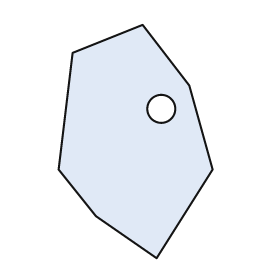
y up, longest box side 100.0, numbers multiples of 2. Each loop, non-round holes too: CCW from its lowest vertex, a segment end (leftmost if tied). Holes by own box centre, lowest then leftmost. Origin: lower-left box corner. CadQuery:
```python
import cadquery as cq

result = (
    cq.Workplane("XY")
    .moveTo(42.0, 0.0)
    .lineTo(66.0, 38.0)
    .lineTo(56.0, 74.0)
    .lineTo(36.0, 100.0)
    .lineTo(6.0, 88.0)
    .lineTo(0.0, 38.0)
    .lineTo(16.0, 18.0)
    .close()
    .moveTo(44.0, 64.0)
    .circle(6.0)
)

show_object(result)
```